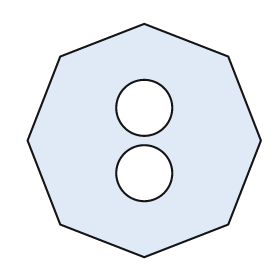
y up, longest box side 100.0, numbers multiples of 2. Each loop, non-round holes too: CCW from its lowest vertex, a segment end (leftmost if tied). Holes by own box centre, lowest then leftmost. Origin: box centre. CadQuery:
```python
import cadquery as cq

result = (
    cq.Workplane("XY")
    .moveTo(0.0, -50.0)
    .lineTo(36.0, -36.0)
    .lineTo(50.0, 0.0)
    .lineTo(36.0, 36.0)
    .lineTo(0.0, 50.0)
    .lineTo(-36.0, 36.0)
    .lineTo(-50.0, 0.0)
    .lineTo(-36.0, -36.0)
    .close()
    .moveTo(0.0, -14.0)
    .circle(12.0)
    .moveTo(0.0, 14.0)
    .circle(12.0)
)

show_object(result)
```